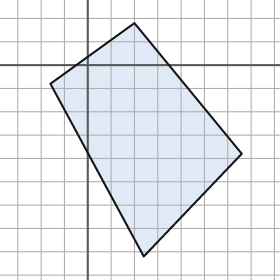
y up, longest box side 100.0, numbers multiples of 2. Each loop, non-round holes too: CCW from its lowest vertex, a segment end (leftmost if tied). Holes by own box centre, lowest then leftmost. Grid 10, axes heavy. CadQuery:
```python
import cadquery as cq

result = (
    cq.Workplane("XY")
    .moveTo(24.0, -82.0)
    .lineTo(66.0, -38.0)
    .lineTo(20.0, 18.0)
    .lineTo(-16.0, -8.0)
    .close()
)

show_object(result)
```